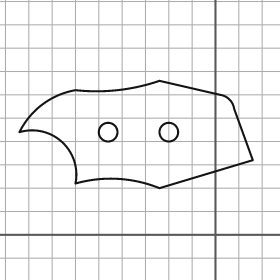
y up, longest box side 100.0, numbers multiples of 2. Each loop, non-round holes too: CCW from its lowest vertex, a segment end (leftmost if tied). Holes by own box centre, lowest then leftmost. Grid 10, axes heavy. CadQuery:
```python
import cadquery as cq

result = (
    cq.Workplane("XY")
    .moveTo(-24.0, 20.0)
    .lineTo(16.0, 32.0)
    .lineTo(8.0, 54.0)
    .threePointArc((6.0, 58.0), (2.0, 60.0))
    .lineTo(-24.0, 66.0)
    .threePointArc((-42.0, 62.0), (-60.0, 62.0))
    .threePointArc((-74.0, 56.0), (-84.0, 44.0))
    .threePointArc((-66.0, 40.0), (-60.0, 22.0))
    .threePointArc((-42.0, 24.0), (-24.0, 20.0))
    .close()
    .moveTo(-46.0, 44.0)
    .circle(4.0)
    .moveTo(-20.0, 44.0)
    .circle(4.0)
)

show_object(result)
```